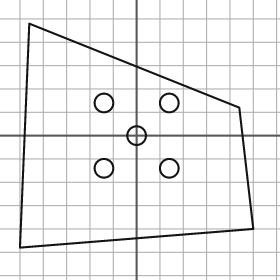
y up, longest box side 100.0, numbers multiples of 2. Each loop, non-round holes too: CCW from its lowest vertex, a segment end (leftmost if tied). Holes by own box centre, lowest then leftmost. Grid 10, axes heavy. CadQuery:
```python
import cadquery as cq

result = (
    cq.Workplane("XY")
    .moveTo(-50.0, -48.0)
    .lineTo(50.0, -40.0)
    .lineTo(44.0, 12.0)
    .lineTo(-46.0, 48.0)
    .close()
    .moveTo(-14.0, -14.0)
    .circle(4.0)
    .moveTo(14.0, -14.0)
    .circle(4.0)
    .moveTo(0.0, 0.0)
    .circle(4.0)
    .moveTo(-14.0, 14.0)
    .circle(4.0)
    .moveTo(14.0, 14.0)
    .circle(4.0)
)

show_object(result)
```